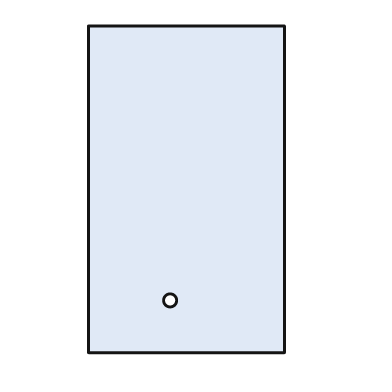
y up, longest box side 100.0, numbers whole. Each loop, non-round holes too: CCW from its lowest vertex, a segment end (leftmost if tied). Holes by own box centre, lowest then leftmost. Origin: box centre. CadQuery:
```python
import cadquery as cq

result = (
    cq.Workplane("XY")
    .moveTo(-30.0, -50.0)
    .lineTo(30.0, -50.0)
    .lineTo(30.0, 50.0)
    .lineTo(-30.0, 50.0)
    .close()
    .moveTo(-5.0, -34.0)
    .circle(2.0)
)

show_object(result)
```